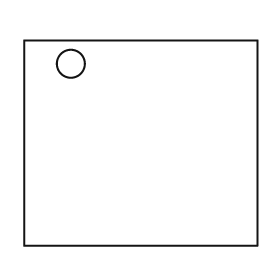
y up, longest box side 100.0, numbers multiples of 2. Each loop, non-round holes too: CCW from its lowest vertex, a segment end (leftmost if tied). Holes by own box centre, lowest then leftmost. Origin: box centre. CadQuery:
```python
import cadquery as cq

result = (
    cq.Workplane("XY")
    .moveTo(-50.0, -44.0)
    .lineTo(50.0, -44.0)
    .lineTo(50.0, 44.0)
    .lineTo(-50.0, 44.0)
    .close()
    .moveTo(-30.0, 34.0)
    .circle(6.0)
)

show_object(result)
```